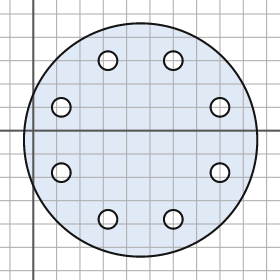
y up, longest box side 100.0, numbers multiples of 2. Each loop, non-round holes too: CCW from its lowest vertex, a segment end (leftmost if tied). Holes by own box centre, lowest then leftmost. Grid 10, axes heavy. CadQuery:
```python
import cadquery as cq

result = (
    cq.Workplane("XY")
    .moveTo(46.0, -4.0)
    .circle(50.0)
    .moveTo(32.0, -38.0)
    .circle(4.0)
    .moveTo(60.0, -38.0)
    .circle(4.0)
    .moveTo(12.0, -18.0)
    .circle(4.0)
    .moveTo(80.0, -18.0)
    .circle(4.0)
    .moveTo(12.0, 10.0)
    .circle(4.0)
    .moveTo(80.0, 10.0)
    .circle(4.0)
    .moveTo(32.0, 30.0)
    .circle(4.0)
    .moveTo(60.0, 30.0)
    .circle(4.0)
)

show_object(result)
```